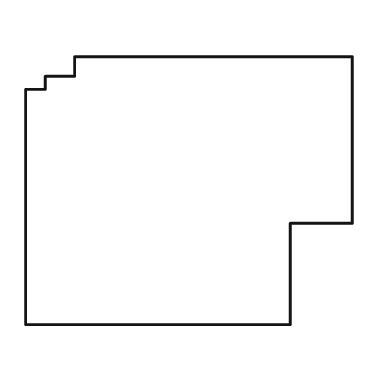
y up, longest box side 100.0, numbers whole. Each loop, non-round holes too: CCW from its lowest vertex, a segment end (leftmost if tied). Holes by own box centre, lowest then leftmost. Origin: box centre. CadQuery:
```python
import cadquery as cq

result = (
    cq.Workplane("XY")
    .moveTo(-50.0, -41.0)
    .lineTo(31.0, -41.0)
    .lineTo(31.0, -10.0)
    .lineTo(50.0, -10.0)
    .lineTo(50.0, 41.0)
    .lineTo(-35.0, 41.0)
    .lineTo(-35.0, 35.0)
    .lineTo(-44.0, 35.0)
    .lineTo(-44.0, 31.0)
    .lineTo(-50.0, 31.0)
    .close()
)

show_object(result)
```